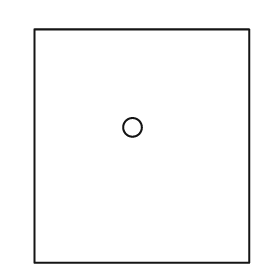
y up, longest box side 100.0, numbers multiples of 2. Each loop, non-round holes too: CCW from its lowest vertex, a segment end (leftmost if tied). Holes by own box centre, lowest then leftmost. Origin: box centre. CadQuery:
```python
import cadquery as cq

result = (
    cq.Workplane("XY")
    .moveTo(-46.0, -50.0)
    .lineTo(46.0, -50.0)
    .lineTo(46.0, 50.0)
    .lineTo(-46.0, 50.0)
    .close()
    .moveTo(-4.0, 8.0)
    .circle(4.0)
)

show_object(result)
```